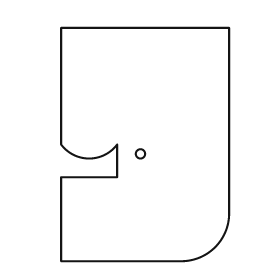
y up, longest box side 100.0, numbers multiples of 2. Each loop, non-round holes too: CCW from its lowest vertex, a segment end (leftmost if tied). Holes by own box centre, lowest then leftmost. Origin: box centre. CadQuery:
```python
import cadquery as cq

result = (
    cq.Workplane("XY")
    .moveTo(-36.0, -50.0)
    .lineTo(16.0, -50.0)
    .threePointArc((30.0, -44.0), (36.0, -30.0))
    .lineTo(36.0, 50.0)
    .lineTo(-36.0, 50.0)
    .lineTo(-36.0, 0.0)
    .threePointArc((-24.0, -6.0), (-12.0, 0.0))
    .lineTo(-12.0, -14.0)
    .lineTo(-36.0, -14.0)
    .close()
    .moveTo(-2.0, -4.0)
    .circle(2.0)
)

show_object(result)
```